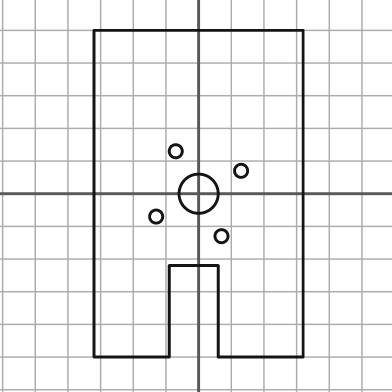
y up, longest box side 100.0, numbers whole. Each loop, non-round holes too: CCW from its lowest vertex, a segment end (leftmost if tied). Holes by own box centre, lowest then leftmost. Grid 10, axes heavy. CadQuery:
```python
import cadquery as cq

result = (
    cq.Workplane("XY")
    .moveTo(-32.0, -50.0)
    .lineTo(-9.0, -50.0)
    .lineTo(-9.0, -22.0)
    .lineTo(6.0, -22.0)
    .lineTo(6.0, -50.0)
    .lineTo(32.0, -50.0)
    .lineTo(32.0, 50.0)
    .lineTo(-32.0, 50.0)
    .close()
    .moveTo(7.0, -13.0)
    .circle(2.0)
    .moveTo(-13.0, -7.0)
    .circle(2.0)
    .moveTo(0.0, 0.0)
    .circle(6.0)
    .moveTo(13.0, 7.0)
    .circle(2.0)
    .moveTo(-7.0, 13.0)
    .circle(2.0)
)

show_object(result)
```